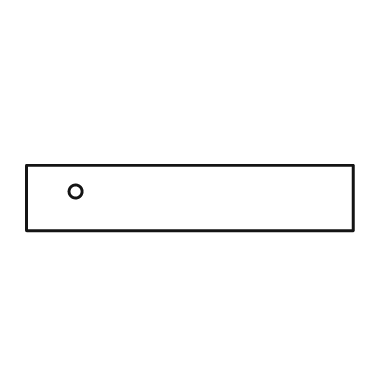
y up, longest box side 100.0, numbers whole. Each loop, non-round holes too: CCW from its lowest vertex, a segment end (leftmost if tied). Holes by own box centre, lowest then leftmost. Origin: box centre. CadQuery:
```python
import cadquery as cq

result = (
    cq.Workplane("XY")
    .moveTo(-50.0, -10.0)
    .lineTo(50.0, -10.0)
    .lineTo(50.0, 10.0)
    .lineTo(-50.0, 10.0)
    .close()
    .moveTo(-35.0, 2.0)
    .circle(2.0)
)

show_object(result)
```